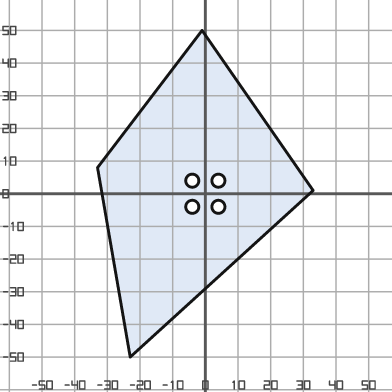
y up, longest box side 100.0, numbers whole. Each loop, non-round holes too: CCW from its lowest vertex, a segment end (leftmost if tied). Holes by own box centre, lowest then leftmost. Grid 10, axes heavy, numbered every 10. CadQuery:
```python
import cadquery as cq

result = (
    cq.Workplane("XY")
    .moveTo(-23.0, -50.0)
    .lineTo(33.0, 1.0)
    .lineTo(-1.0, 50.0)
    .lineTo(-33.0, 8.0)
    .close()
    .moveTo(-4.0, -4.0)
    .circle(2.0)
    .moveTo(4.0, -4.0)
    .circle(2.0)
    .moveTo(-4.0, 4.0)
    .circle(2.0)
    .moveTo(4.0, 4.0)
    .circle(2.0)
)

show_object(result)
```